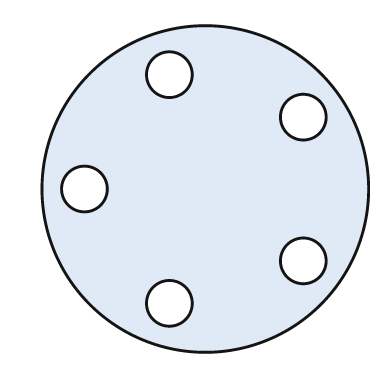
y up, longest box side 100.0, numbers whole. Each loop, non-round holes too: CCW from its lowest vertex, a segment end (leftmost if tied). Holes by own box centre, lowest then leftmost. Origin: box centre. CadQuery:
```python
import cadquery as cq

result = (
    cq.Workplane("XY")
    .moveTo(0.0, 0.0)
    .circle(50.0)
    .moveTo(-11.0, -35.0)
    .circle(7.0)
    .moveTo(30.0, -22.0)
    .circle(7.0)
    .moveTo(-37.0, 0.0)
    .circle(7.0)
    .moveTo(30.0, 22.0)
    .circle(7.0)
    .moveTo(-11.0, 35.0)
    .circle(7.0)
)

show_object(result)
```